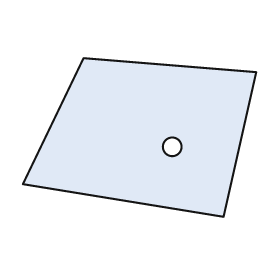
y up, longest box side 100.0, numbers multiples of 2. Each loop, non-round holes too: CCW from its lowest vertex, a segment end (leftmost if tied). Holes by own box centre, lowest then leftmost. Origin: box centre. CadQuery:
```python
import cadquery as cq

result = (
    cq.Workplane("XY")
    .moveTo(36.0, -34.0)
    .lineTo(50.0, 28.0)
    .lineTo(-24.0, 34.0)
    .lineTo(-50.0, -20.0)
    .close()
    .moveTo(14.0, -4.0)
    .circle(4.0)
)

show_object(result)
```